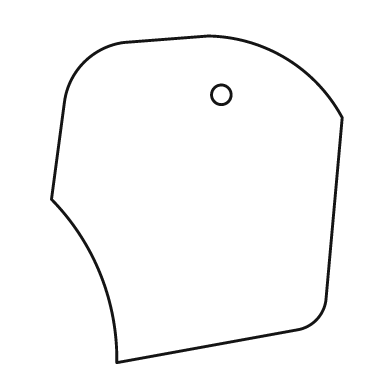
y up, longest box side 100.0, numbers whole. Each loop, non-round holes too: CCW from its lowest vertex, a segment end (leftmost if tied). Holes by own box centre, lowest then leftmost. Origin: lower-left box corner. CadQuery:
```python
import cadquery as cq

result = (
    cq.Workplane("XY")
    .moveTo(20.0, 0.0)
    .lineTo(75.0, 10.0)
    .threePointArc((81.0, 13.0), (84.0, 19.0))
    .lineTo(89.0, 75.0)
    .threePointArc((72.0, 93.0), (48.0, 100.0))
    .lineTo(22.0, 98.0)
    .threePointArc((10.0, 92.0), (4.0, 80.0))
    .lineTo(0.0, 50.0)
    .threePointArc((15.0, 27.0), (20.0, 0.0))
    .close()
    .moveTo(52.0, 82.0)
    .circle(3.0)
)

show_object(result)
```